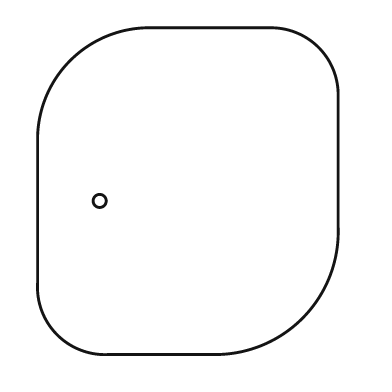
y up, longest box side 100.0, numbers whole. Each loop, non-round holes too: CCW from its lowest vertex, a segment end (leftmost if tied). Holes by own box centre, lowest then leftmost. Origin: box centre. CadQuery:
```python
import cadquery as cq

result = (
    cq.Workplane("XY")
    .moveTo(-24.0, -50.0)
    .lineTo(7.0, -50.0)
    .threePointArc((35.0, -39.0), (46.0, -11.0))
    .lineTo(46.0, 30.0)
    .threePointArc((40.0, 44.0), (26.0, 50.0))
    .lineTo(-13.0, 50.0)
    .threePointArc((-36.0, 40.0), (-46.0, 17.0))
    .lineTo(-46.0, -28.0)
    .threePointArc((-40.0, -44.0), (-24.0, -50.0))
    .close()
    .moveTo(-27.0, -3.0)
    .circle(2.0)
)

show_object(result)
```